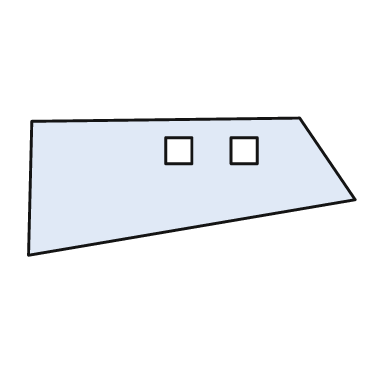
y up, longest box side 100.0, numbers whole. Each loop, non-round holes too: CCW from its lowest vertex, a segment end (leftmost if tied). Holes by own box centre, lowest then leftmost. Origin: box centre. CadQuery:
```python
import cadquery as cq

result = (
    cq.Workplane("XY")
    .moveTo(-50.0, -21.0)
    .lineTo(50.0, -4.0)
    .lineTo(33.0, 21.0)
    .lineTo(-49.0, 20.0)
    .close()
    .moveTo(-8.0, 7.0)
    .lineTo(0.0, 7.0)
    .lineTo(0.0, 15.0)
    .lineTo(-8.0, 15.0)
    .close()
    .moveTo(12.0, 7.0)
    .lineTo(20.0, 7.0)
    .lineTo(20.0, 15.0)
    .lineTo(12.0, 15.0)
    .close()
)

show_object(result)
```